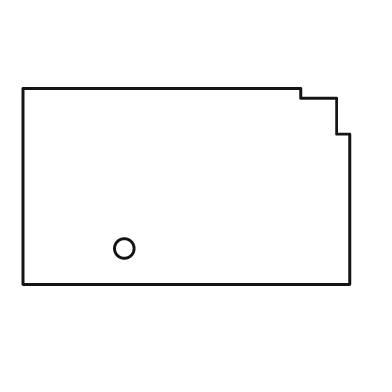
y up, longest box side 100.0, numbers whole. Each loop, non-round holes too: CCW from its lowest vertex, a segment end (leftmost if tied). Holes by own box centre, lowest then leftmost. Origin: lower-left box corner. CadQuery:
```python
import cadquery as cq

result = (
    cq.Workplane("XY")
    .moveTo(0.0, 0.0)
    .lineTo(100.0, 0.0)
    .lineTo(100.0, 46.0)
    .lineTo(96.0, 46.0)
    .lineTo(96.0, 57.0)
    .lineTo(85.0, 57.0)
    .lineTo(85.0, 60.0)
    .lineTo(0.0, 60.0)
    .close()
    .moveTo(31.0, 11.0)
    .circle(3.0)
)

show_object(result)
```